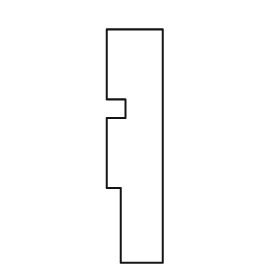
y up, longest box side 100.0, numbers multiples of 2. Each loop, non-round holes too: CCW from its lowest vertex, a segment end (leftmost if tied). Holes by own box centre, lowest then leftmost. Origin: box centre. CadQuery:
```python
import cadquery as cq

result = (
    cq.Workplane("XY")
    .moveTo(-6.0, -50.0)
    .lineTo(12.0, -50.0)
    .lineTo(12.0, 50.0)
    .lineTo(-12.0, 50.0)
    .lineTo(-12.0, 20.0)
    .lineTo(-4.0, 20.0)
    .lineTo(-4.0, 12.0)
    .lineTo(-12.0, 12.0)
    .lineTo(-12.0, -18.0)
    .lineTo(-6.0, -18.0)
    .close()
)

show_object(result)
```